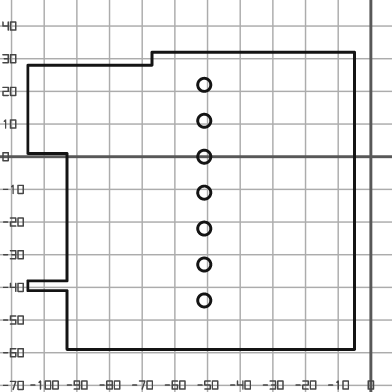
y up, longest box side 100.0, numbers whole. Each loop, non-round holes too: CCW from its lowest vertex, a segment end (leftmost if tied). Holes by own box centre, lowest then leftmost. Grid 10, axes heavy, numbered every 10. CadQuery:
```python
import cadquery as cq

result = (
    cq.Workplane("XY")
    .moveTo(-93.0, -59.0)
    .lineTo(-5.0, -59.0)
    .lineTo(-5.0, 32.0)
    .lineTo(-67.0, 32.0)
    .lineTo(-67.0, 28.0)
    .lineTo(-105.0, 28.0)
    .lineTo(-105.0, 1.0)
    .lineTo(-93.0, 1.0)
    .lineTo(-93.0, -38.0)
    .lineTo(-105.0, -38.0)
    .lineTo(-105.0, -41.0)
    .lineTo(-93.0, -41.0)
    .close()
    .moveTo(-51.0, -44.0)
    .circle(2.0)
    .moveTo(-51.0, -33.0)
    .circle(2.0)
    .moveTo(-51.0, -22.0)
    .circle(2.0)
    .moveTo(-51.0, -11.0)
    .circle(2.0)
    .moveTo(-51.0, 0.0)
    .circle(2.0)
    .moveTo(-51.0, 11.0)
    .circle(2.0)
    .moveTo(-51.0, 22.0)
    .circle(2.0)
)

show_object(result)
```